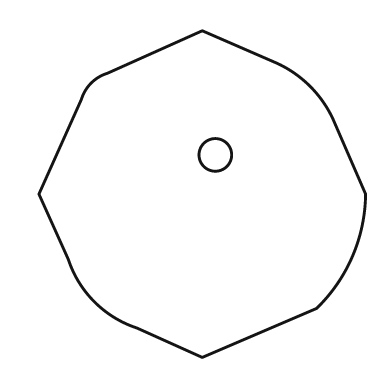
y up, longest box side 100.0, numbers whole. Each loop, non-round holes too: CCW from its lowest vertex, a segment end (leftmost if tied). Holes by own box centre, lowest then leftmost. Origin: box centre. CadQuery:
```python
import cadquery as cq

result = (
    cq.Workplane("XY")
    .moveTo(0.0, -50.0)
    .lineTo(35.0, -35.0)
    .threePointArc((46.0, -19.0), (50.0, 0.0))
    .lineTo(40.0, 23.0)
    .threePointArc((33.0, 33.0), (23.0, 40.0))
    .lineTo(0.0, 50.0)
    .lineTo(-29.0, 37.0)
    .threePointArc((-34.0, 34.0), (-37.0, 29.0))
    .lineTo(-50.0, 0.0)
    .lineTo(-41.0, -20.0)
    .threePointArc((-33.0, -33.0), (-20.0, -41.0))
    .close()
    .moveTo(4.0, 12.0)
    .circle(5.0)
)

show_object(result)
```